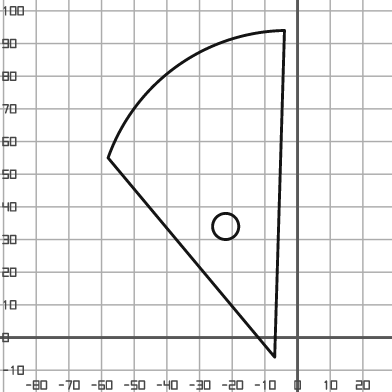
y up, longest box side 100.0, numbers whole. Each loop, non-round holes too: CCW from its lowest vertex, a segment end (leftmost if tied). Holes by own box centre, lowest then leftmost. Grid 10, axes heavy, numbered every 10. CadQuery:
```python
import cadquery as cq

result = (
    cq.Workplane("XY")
    .moveTo(-7.0, -6.0)
    .lineTo(-4.0, 94.0)
    .threePointArc((-37.0, 83.0), (-58.0, 55.0))
    .close()
    .moveTo(-22.0, 34.0)
    .circle(4.0)
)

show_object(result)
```